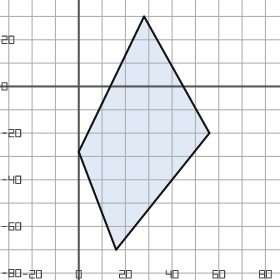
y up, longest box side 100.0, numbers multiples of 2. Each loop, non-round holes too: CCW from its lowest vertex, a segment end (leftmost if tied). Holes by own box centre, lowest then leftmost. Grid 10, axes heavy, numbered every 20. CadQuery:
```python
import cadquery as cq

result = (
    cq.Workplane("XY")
    .moveTo(16.0, -70.0)
    .lineTo(56.0, -20.0)
    .lineTo(28.0, 30.0)
    .lineTo(0.0, -28.0)
    .close()
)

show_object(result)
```